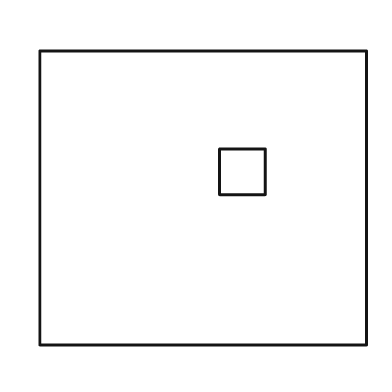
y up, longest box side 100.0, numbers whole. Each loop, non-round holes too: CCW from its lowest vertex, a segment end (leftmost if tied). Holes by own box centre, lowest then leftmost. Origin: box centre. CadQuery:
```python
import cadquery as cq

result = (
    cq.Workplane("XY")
    .moveTo(-50.0, -45.0)
    .lineTo(50.0, -45.0)
    .lineTo(50.0, 45.0)
    .lineTo(-50.0, 45.0)
    .close()
    .moveTo(5.0, 1.0)
    .lineTo(19.0, 1.0)
    .lineTo(19.0, 15.0)
    .lineTo(5.0, 15.0)
    .close()
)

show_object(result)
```